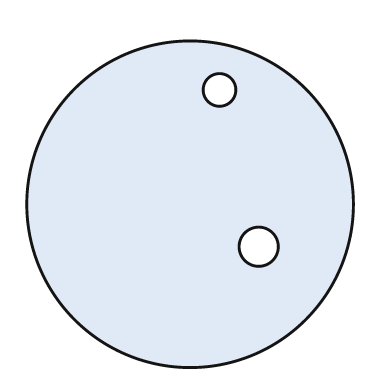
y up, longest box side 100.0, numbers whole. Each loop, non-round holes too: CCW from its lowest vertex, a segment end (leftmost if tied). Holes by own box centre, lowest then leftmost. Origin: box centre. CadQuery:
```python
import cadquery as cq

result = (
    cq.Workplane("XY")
    .moveTo(0.0, 0.0)
    .circle(50.0)
    .moveTo(21.0, -13.0)
    .circle(6.0)
    .moveTo(9.0, 35.0)
    .circle(5.0)
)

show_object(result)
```